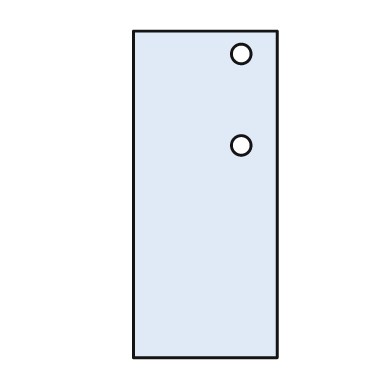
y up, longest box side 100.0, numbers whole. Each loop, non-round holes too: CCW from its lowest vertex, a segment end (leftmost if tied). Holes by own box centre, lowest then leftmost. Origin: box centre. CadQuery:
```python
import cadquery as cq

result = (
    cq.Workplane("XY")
    .moveTo(-22.0, -50.0)
    .lineTo(22.0, -50.0)
    .lineTo(22.0, 50.0)
    .lineTo(-22.0, 50.0)
    .close()
    .moveTo(11.0, 15.0)
    .circle(3.0)
    .moveTo(11.0, 43.0)
    .circle(3.0)
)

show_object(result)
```